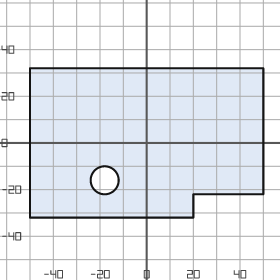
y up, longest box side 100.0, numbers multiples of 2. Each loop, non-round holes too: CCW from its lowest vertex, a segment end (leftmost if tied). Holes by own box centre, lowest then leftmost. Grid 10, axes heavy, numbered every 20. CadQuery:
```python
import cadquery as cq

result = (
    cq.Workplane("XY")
    .moveTo(-50.0, -32.0)
    .lineTo(20.0, -32.0)
    .lineTo(20.0, -22.0)
    .lineTo(50.0, -22.0)
    .lineTo(50.0, 32.0)
    .lineTo(-50.0, 32.0)
    .close()
    .moveTo(-18.0, -16.0)
    .circle(6.0)
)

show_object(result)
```